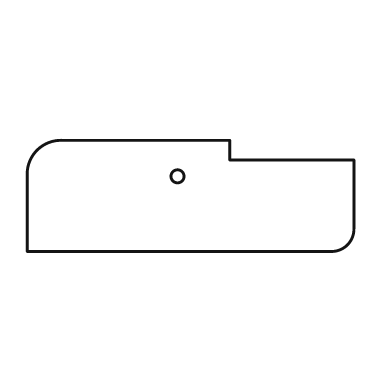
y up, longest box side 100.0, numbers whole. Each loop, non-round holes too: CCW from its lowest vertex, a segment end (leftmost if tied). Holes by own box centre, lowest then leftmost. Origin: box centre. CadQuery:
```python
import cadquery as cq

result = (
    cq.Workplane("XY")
    .moveTo(-50.0, -17.0)
    .lineTo(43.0, -17.0)
    .threePointArc((48.0, -15.0), (50.0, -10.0))
    .lineTo(50.0, 11.0)
    .lineTo(12.0, 11.0)
    .lineTo(12.0, 17.0)
    .lineTo(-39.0, 17.0)
    .threePointArc((-47.0, 14.0), (-50.0, 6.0))
    .close()
    .moveTo(-4.0, 6.0)
    .circle(2.0)
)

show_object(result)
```